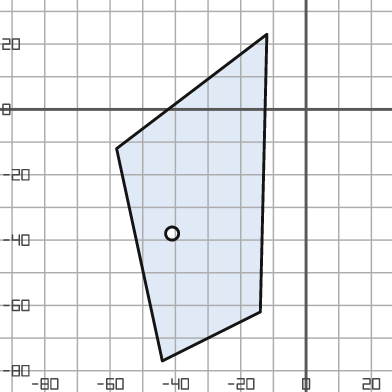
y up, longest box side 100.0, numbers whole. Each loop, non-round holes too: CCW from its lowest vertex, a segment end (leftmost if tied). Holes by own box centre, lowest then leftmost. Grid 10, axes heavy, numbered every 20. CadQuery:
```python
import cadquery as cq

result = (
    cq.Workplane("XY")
    .moveTo(-44.0, -77.0)
    .lineTo(-14.0, -62.0)
    .lineTo(-12.0, 23.0)
    .lineTo(-58.0, -12.0)
    .close()
    .moveTo(-41.0, -38.0)
    .circle(2.0)
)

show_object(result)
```